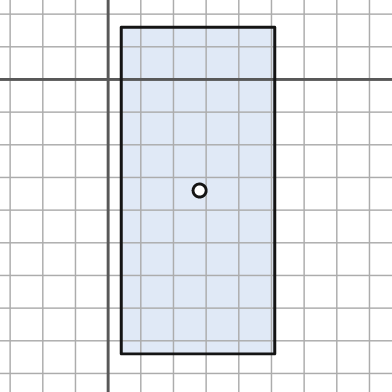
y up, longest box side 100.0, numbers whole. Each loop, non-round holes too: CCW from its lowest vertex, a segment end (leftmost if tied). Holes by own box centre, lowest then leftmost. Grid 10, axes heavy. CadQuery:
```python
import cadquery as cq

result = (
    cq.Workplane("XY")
    .moveTo(4.0, -84.0)
    .lineTo(51.0, -84.0)
    .lineTo(51.0, 16.0)
    .lineTo(4.0, 16.0)
    .close()
    .moveTo(28.0, -34.0)
    .circle(2.0)
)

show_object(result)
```